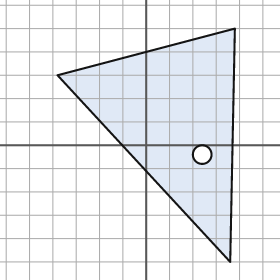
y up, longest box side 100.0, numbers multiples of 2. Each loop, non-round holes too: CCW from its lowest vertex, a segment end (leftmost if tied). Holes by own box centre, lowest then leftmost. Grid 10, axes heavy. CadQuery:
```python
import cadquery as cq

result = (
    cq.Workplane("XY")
    .moveTo(36.0, -50.0)
    .lineTo(38.0, 50.0)
    .lineTo(-38.0, 30.0)
    .close()
    .moveTo(24.0, -4.0)
    .circle(4.0)
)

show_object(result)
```